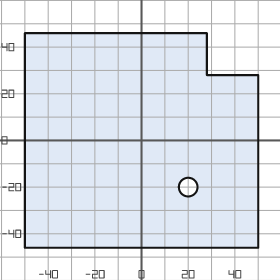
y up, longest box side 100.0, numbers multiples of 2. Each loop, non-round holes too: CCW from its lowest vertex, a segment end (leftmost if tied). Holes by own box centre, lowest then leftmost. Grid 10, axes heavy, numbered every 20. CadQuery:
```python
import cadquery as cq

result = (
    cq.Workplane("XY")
    .moveTo(-50.0, -46.0)
    .lineTo(50.0, -46.0)
    .lineTo(50.0, 28.0)
    .lineTo(28.0, 28.0)
    .lineTo(28.0, 46.0)
    .lineTo(-50.0, 46.0)
    .close()
    .moveTo(20.0, -20.0)
    .circle(4.0)
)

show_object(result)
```